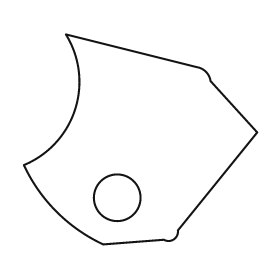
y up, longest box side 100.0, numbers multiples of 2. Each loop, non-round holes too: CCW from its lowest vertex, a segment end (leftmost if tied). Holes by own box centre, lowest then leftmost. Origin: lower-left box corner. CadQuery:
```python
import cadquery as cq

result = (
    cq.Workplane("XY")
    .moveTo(34.0, 0.0)
    .lineTo(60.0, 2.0)
    .threePointArc((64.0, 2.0), (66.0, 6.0))
    .lineTo(100.0, 48.0)
    .lineTo(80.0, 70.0)
    .threePointArc((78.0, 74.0), (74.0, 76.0))
    .lineTo(18.0, 90.0)
    .threePointArc((22.0, 58.0), (0.0, 34.0))
    .threePointArc((14.0, 14.0), (34.0, 0.0))
    .close()
    .moveTo(40.0, 20.0)
    .circle(10.0)
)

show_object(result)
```